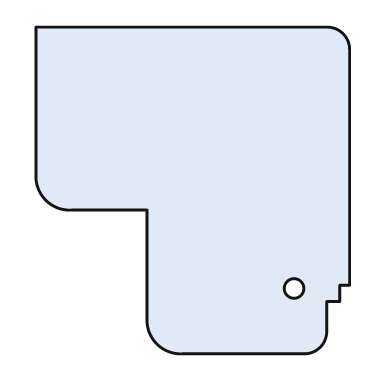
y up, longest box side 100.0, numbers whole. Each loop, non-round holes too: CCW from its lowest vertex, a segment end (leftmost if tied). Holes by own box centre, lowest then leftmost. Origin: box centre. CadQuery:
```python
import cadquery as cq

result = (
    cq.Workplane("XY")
    .moveTo(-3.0, -50.0)
    .lineTo(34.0, -50.0)
    .threePointArc((39.0, -48.0), (41.0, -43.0))
    .lineTo(41.0, -34.0)
    .lineTo(45.0, -34.0)
    .lineTo(45.0, -29.0)
    .lineTo(48.0, -29.0)
    .lineTo(48.0, 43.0)
    .threePointArc((46.0, 48.0), (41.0, 50.0))
    .lineTo(-48.0, 50.0)
    .lineTo(-48.0, 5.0)
    .threePointArc((-45.0, -3.0), (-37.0, -6.0))
    .lineTo(-14.0, -6.0)
    .lineTo(-14.0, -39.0)
    .threePointArc((-11.0, -47.0), (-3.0, -50.0))
    .close()
    .moveTo(31.0, -30.0)
    .circle(3.0)
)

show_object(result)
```